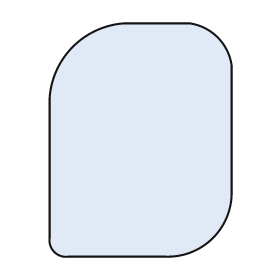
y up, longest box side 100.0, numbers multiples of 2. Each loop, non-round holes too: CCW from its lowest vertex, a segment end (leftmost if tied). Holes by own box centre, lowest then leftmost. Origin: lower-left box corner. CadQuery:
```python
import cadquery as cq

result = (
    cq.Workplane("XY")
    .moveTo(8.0, 0.0)
    .lineTo(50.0, 0.0)
    .threePointArc((70.0, 8.0), (78.0, 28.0))
    .lineTo(78.0, 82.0)
    .threePointArc((72.0, 94.0), (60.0, 100.0))
    .lineTo(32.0, 100.0)
    .threePointArc((10.0, 90.0), (0.0, 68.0))
    .lineTo(0.0, 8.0)
    .threePointArc((2.0, 2.0), (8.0, 0.0))
    .close()
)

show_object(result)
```